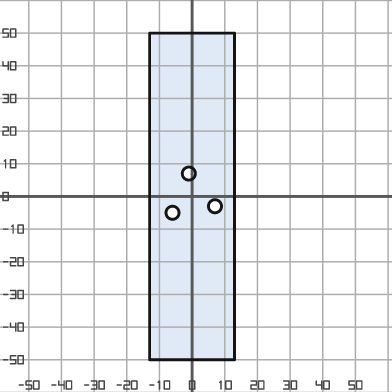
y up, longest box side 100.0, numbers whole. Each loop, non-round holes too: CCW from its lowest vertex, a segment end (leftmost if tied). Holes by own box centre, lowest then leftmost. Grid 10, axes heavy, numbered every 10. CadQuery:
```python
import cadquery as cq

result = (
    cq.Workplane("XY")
    .moveTo(-13.0, -50.0)
    .lineTo(13.0, -50.0)
    .lineTo(13.0, 50.0)
    .lineTo(-13.0, 50.0)
    .close()
    .moveTo(-6.0, -5.0)
    .circle(2.0)
    .moveTo(7.0, -3.0)
    .circle(2.0)
    .moveTo(-1.0, 7.0)
    .circle(2.0)
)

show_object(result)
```